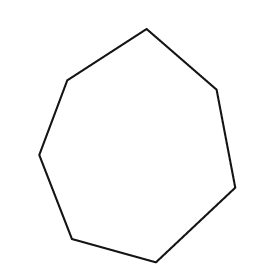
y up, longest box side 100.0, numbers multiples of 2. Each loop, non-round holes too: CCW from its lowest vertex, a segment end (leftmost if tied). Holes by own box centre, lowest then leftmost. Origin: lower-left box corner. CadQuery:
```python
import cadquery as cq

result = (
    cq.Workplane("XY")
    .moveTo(50.0, 0.0)
    .lineTo(84.0, 32.0)
    .lineTo(76.0, 74.0)
    .lineTo(46.0, 100.0)
    .lineTo(12.0, 78.0)
    .lineTo(0.0, 46.0)
    .lineTo(14.0, 10.0)
    .close()
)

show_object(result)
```